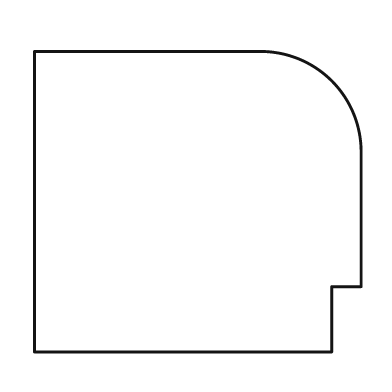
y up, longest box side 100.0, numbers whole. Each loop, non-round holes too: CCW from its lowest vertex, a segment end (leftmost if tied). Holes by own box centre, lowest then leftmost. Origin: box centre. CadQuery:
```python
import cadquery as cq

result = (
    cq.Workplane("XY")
    .moveTo(-50.0, -46.0)
    .lineTo(41.0, -46.0)
    .lineTo(41.0, -26.0)
    .lineTo(50.0, -26.0)
    .lineTo(50.0, 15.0)
    .threePointArc((41.0, 37.0), (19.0, 46.0))
    .lineTo(-50.0, 46.0)
    .close()
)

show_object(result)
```